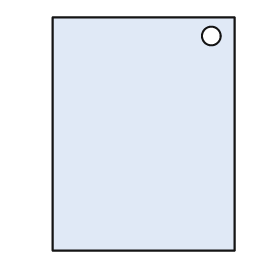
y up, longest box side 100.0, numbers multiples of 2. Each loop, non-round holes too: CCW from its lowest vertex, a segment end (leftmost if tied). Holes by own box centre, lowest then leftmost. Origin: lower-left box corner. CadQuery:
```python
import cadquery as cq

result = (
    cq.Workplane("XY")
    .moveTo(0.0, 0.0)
    .lineTo(78.0, 0.0)
    .lineTo(78.0, 100.0)
    .lineTo(0.0, 100.0)
    .close()
    .moveTo(68.0, 92.0)
    .circle(4.0)
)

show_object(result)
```